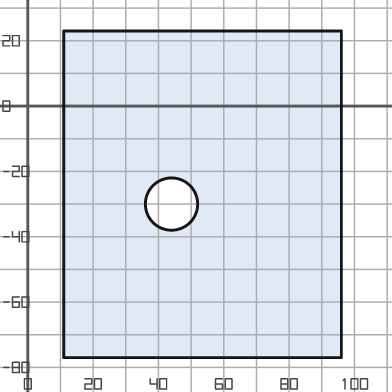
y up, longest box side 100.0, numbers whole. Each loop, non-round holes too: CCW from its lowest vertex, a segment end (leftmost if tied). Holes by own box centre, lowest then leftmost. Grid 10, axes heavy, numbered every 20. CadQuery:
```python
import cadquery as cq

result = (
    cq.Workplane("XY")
    .moveTo(11.0, -77.0)
    .lineTo(96.0, -77.0)
    .lineTo(96.0, 23.0)
    .lineTo(11.0, 23.0)
    .close()
    .moveTo(44.0, -30.0)
    .circle(8.0)
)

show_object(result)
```